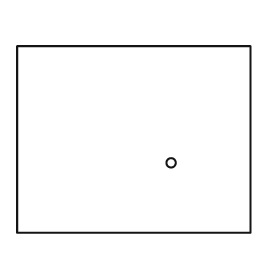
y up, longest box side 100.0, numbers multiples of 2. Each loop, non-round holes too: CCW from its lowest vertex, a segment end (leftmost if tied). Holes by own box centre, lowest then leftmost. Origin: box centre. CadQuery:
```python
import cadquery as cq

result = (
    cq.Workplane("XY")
    .moveTo(-50.0, -40.0)
    .lineTo(50.0, -40.0)
    .lineTo(50.0, 40.0)
    .lineTo(-50.0, 40.0)
    .close()
    .moveTo(16.0, -10.0)
    .circle(2.0)
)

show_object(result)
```